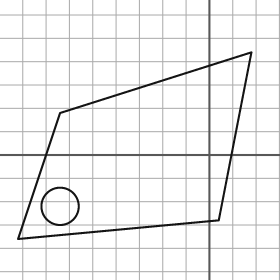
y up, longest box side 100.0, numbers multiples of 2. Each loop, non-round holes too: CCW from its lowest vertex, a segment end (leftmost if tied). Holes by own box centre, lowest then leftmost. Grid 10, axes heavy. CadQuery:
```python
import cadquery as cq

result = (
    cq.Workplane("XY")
    .moveTo(-82.0, -36.0)
    .lineTo(4.0, -28.0)
    .lineTo(18.0, 44.0)
    .lineTo(-64.0, 18.0)
    .close()
    .moveTo(-64.0, -22.0)
    .circle(8.0)
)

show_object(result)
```